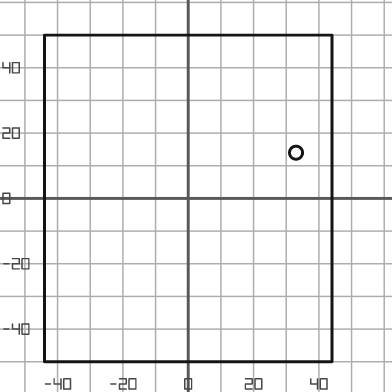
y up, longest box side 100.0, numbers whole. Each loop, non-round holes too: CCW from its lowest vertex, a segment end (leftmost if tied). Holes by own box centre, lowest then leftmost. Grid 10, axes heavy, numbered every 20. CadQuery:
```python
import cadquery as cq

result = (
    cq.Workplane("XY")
    .moveTo(-44.0, -50.0)
    .lineTo(44.0, -50.0)
    .lineTo(44.0, 50.0)
    .lineTo(-44.0, 50.0)
    .close()
    .moveTo(33.0, 14.0)
    .circle(2.0)
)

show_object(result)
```